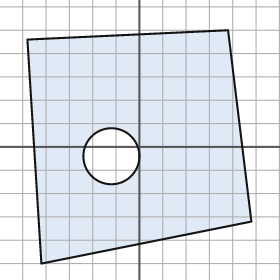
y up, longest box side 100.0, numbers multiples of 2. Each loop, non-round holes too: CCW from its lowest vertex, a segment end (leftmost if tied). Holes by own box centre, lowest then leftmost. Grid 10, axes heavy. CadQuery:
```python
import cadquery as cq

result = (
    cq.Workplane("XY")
    .moveTo(-42.0, -50.0)
    .lineTo(48.0, -32.0)
    .lineTo(38.0, 50.0)
    .lineTo(-48.0, 46.0)
    .close()
    .moveTo(-12.0, -4.0)
    .circle(12.0)
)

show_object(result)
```